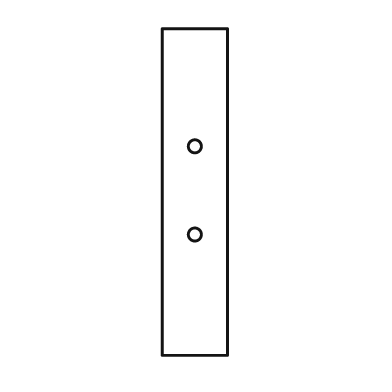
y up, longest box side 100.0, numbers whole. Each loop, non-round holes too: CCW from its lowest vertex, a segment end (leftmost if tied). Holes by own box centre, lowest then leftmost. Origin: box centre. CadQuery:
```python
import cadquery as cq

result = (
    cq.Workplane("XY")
    .moveTo(-10.0, -50.0)
    .lineTo(10.0, -50.0)
    .lineTo(10.0, 50.0)
    .lineTo(-10.0, 50.0)
    .close()
    .moveTo(0.0, -13.0)
    .circle(2.0)
    .moveTo(0.0, 14.0)
    .circle(2.0)
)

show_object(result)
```